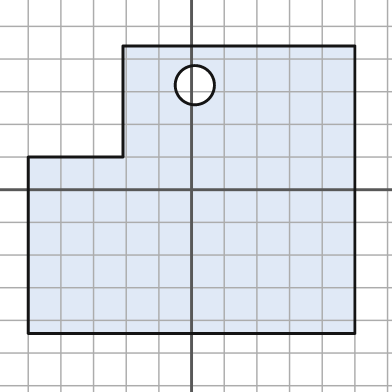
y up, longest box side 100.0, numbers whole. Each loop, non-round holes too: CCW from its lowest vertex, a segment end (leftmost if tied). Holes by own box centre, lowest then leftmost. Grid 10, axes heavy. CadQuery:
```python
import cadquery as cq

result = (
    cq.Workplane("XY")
    .moveTo(-50.0, -44.0)
    .lineTo(50.0, -44.0)
    .lineTo(50.0, 44.0)
    .lineTo(-21.0, 44.0)
    .lineTo(-21.0, 10.0)
    .lineTo(-50.0, 10.0)
    .close()
    .moveTo(1.0, 32.0)
    .circle(6.0)
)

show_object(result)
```